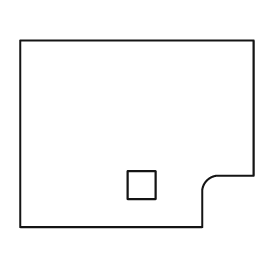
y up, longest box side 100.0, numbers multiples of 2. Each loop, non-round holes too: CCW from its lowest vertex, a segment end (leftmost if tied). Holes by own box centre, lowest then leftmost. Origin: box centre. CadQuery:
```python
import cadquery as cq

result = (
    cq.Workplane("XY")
    .moveTo(-50.0, -40.0)
    .lineTo(28.0, -40.0)
    .lineTo(28.0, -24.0)
    .threePointArc((30.0, -20.0), (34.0, -18.0))
    .lineTo(50.0, -18.0)
    .lineTo(50.0, 40.0)
    .lineTo(-50.0, 40.0)
    .close()
    .moveTo(-4.0, -28.0)
    .lineTo(8.0, -28.0)
    .lineTo(8.0, -16.0)
    .lineTo(-4.0, -16.0)
    .close()
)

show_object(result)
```